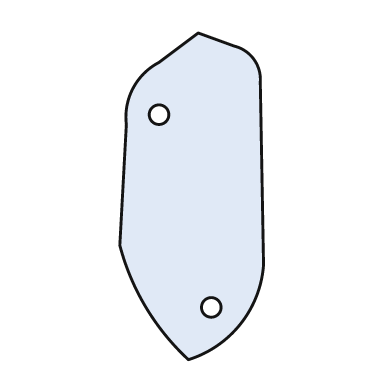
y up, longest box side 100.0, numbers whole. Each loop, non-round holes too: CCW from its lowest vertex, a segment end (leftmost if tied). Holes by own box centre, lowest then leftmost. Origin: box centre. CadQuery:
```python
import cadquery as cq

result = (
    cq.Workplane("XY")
    .moveTo(-1.0, -50.0)
    .threePointArc((15.0, -39.0), (22.0, -21.0))
    .lineTo(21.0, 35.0)
    .threePointArc((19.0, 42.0), (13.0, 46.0))
    .lineTo(2.0, 50.0)
    .lineTo(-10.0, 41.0)
    .threePointArc((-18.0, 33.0), (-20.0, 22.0))
    .lineTo(-22.0, -15.0)
    .threePointArc((-14.0, -34.0), (-1.0, -50.0))
    .close()
    .moveTo(6.0, -34.0)
    .circle(3.0)
    .moveTo(-10.0, 25.0)
    .circle(3.0)
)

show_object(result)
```